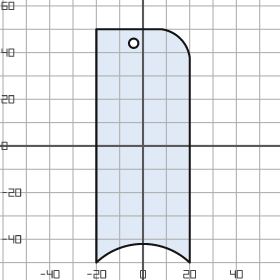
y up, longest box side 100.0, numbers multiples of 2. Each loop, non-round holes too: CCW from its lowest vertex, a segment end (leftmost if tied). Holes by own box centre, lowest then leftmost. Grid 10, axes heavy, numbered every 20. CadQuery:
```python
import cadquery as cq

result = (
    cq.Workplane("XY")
    .moveTo(-20.0, -50.0)
    .threePointArc((0.0, -42.0), (20.0, -50.0))
    .lineTo(20.0, 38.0)
    .threePointArc((16.0, 46.0), (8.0, 50.0))
    .lineTo(-20.0, 50.0)
    .close()
    .moveTo(-4.0, 44.0)
    .circle(2.0)
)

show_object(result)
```